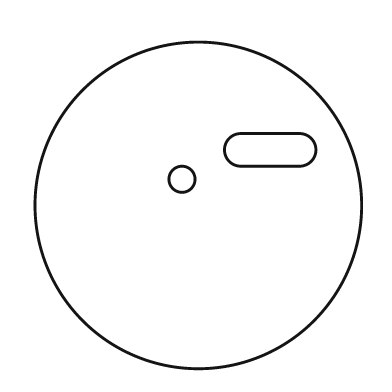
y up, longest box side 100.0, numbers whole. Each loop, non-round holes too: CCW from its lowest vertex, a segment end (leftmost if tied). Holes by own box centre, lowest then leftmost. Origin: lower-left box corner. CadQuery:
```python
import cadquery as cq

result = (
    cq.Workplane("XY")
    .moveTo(50.0, 50.0)
    .circle(50.0)
    .moveTo(45.0, 58.0)
    .circle(4.0)
    .moveTo(63.0, 62.0)
    .lineTo(81.0, 62.0)
    .threePointArc((86.0, 67.0), (81.0, 72.0))
    .lineTo(63.0, 72.0)
    .threePointArc((58.0, 67.0), (63.0, 62.0))
    .close()
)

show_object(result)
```